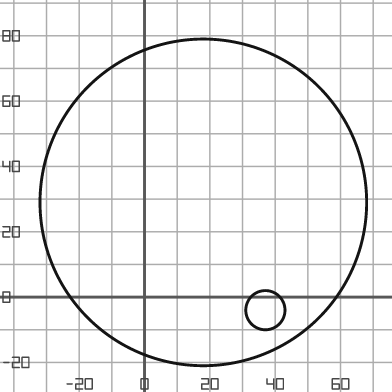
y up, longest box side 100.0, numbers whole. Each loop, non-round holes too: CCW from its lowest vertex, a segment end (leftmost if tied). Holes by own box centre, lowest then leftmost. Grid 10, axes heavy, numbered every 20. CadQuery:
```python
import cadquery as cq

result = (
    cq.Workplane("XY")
    .moveTo(18.0, 29.0)
    .circle(50.0)
    .moveTo(37.0, -4.0)
    .circle(6.0)
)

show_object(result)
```